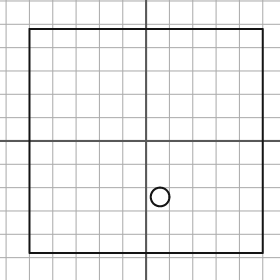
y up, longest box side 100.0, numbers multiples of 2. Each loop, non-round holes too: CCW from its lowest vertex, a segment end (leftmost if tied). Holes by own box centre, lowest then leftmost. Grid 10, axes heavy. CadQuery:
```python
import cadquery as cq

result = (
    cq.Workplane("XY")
    .moveTo(-50.0, -48.0)
    .lineTo(50.0, -48.0)
    .lineTo(50.0, 48.0)
    .lineTo(-50.0, 48.0)
    .close()
    .moveTo(6.0, -24.0)
    .circle(4.0)
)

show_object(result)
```